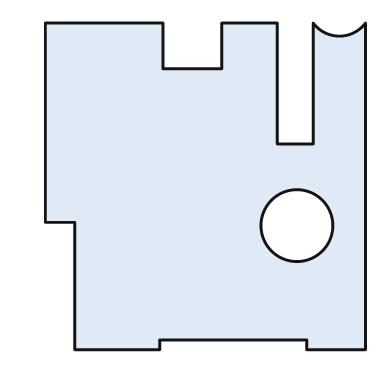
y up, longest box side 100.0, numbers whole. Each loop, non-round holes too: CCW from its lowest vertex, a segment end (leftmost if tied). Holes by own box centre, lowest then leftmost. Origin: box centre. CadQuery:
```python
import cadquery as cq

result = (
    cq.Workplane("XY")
    .moveTo(-40.0, -50.0)
    .lineTo(-14.0, -50.0)
    .lineTo(-14.0, -47.0)
    .lineTo(31.0, -47.0)
    .lineTo(31.0, -50.0)
    .lineTo(49.0, -50.0)
    .lineTo(49.0, 50.0)
    .threePointArc((41.0, 46.0), (33.0, 50.0))
    .lineTo(33.0, 13.0)
    .lineTo(22.0, 13.0)
    .lineTo(22.0, 50.0)
    .lineTo(5.0, 50.0)
    .lineTo(5.0, 36.0)
    .lineTo(-13.0, 36.0)
    .lineTo(-13.0, 50.0)
    .lineTo(-49.0, 50.0)
    .lineTo(-49.0, -11.0)
    .lineTo(-40.0, -11.0)
    .close()
    .moveTo(28.0, -12.0)
    .circle(11.0)
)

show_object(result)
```